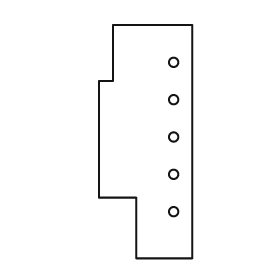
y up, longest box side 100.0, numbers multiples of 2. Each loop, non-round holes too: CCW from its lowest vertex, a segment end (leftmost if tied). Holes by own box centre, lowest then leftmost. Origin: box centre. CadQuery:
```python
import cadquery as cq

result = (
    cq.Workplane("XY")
    .moveTo(-4.0, -50.0)
    .lineTo(20.0, -50.0)
    .lineTo(20.0, 50.0)
    .lineTo(-14.0, 50.0)
    .lineTo(-14.0, 26.0)
    .lineTo(-20.0, 26.0)
    .lineTo(-20.0, -24.0)
    .lineTo(-4.0, -24.0)
    .close()
    .moveTo(12.0, -30.0)
    .circle(2.0)
    .moveTo(12.0, -14.0)
    .circle(2.0)
    .moveTo(12.0, 2.0)
    .circle(2.0)
    .moveTo(12.0, 18.0)
    .circle(2.0)
    .moveTo(12.0, 34.0)
    .circle(2.0)
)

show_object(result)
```